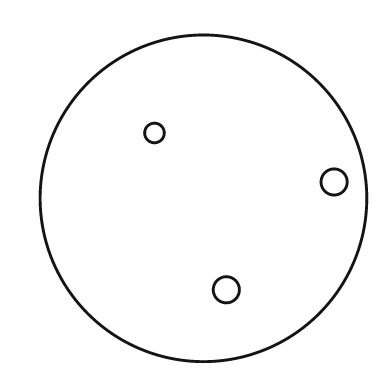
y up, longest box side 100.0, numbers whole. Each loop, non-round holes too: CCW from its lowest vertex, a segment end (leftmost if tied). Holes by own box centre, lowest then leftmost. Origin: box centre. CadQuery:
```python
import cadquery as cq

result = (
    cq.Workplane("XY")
    .moveTo(0.0, 0.0)
    .circle(50.0)
    .moveTo(7.0, -28.0)
    .circle(4.0)
    .moveTo(40.0, 5.0)
    .circle(4.0)
    .moveTo(-15.0, 20.0)
    .circle(3.0)
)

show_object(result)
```